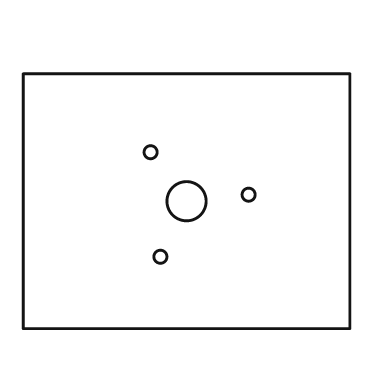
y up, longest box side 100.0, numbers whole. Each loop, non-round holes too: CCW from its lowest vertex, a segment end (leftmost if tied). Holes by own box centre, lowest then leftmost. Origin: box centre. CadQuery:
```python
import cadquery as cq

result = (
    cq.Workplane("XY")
    .moveTo(-50.0, -39.0)
    .lineTo(50.0, -39.0)
    .lineTo(50.0, 39.0)
    .lineTo(-50.0, 39.0)
    .close()
    .moveTo(-8.0, -17.0)
    .circle(2.0)
    .moveTo(0.0, 0.0)
    .circle(6.0)
    .moveTo(19.0, 2.0)
    .circle(2.0)
    .moveTo(-11.0, 15.0)
    .circle(2.0)
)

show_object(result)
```